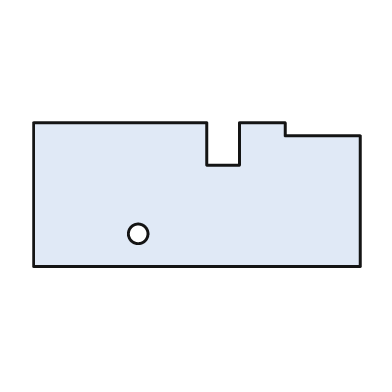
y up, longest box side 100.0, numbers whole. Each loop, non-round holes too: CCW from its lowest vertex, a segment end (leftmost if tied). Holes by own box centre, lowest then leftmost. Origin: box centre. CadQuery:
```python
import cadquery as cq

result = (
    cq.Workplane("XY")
    .moveTo(-50.0, -22.0)
    .lineTo(50.0, -22.0)
    .lineTo(50.0, 18.0)
    .lineTo(27.0, 18.0)
    .lineTo(27.0, 22.0)
    .lineTo(13.0, 22.0)
    .lineTo(13.0, 9.0)
    .lineTo(3.0, 9.0)
    .lineTo(3.0, 22.0)
    .lineTo(-50.0, 22.0)
    .close()
    .moveTo(-18.0, -12.0)
    .circle(3.0)
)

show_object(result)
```